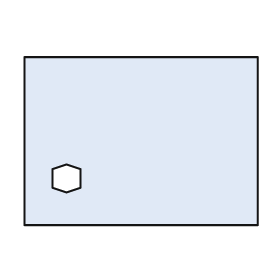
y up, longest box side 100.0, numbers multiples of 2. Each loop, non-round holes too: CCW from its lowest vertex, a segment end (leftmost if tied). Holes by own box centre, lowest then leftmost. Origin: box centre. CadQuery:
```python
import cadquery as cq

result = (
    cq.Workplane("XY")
    .moveTo(-50.0, -36.0)
    .lineTo(50.0, -36.0)
    .lineTo(50.0, 36.0)
    .lineTo(-50.0, 36.0)
    .close()
    .moveTo(-32.0, -22.0)
    .lineTo(-26.0, -20.0)
    .lineTo(-26.0, -12.0)
    .lineTo(-32.0, -10.0)
    .lineTo(-38.0, -12.0)
    .lineTo(-38.0, -20.0)
    .close()
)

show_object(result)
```